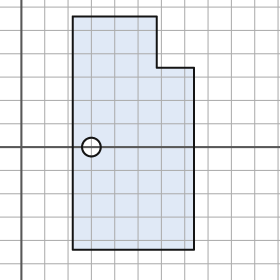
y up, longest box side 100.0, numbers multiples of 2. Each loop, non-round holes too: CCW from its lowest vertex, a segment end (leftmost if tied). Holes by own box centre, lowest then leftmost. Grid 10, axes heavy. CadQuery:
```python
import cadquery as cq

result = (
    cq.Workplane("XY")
    .moveTo(22.0, -44.0)
    .lineTo(74.0, -44.0)
    .lineTo(74.0, 34.0)
    .lineTo(58.0, 34.0)
    .lineTo(58.0, 56.0)
    .lineTo(22.0, 56.0)
    .close()
    .moveTo(30.0, 0.0)
    .circle(4.0)
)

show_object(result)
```